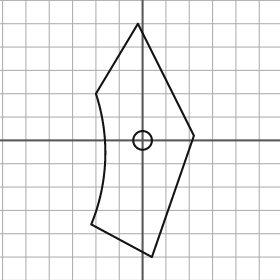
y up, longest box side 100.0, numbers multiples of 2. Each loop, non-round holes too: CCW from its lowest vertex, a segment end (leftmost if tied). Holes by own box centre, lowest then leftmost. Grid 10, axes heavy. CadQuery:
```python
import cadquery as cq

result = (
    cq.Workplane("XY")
    .moveTo(4.0, -50.0)
    .lineTo(22.0, 2.0)
    .lineTo(-2.0, 50.0)
    .lineTo(-20.0, 20.0)
    .threePointArc((-16.0, -8.0), (-22.0, -36.0))
    .close()
    .moveTo(0.0, 0.0)
    .circle(4.0)
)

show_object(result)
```